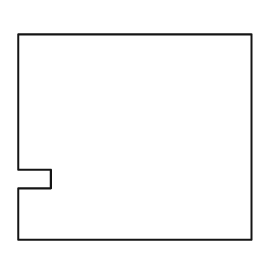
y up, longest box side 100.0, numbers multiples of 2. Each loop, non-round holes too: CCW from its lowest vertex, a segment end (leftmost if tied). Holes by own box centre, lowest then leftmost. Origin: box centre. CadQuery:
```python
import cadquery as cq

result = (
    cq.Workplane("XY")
    .moveTo(-50.0, -44.0)
    .lineTo(50.0, -44.0)
    .lineTo(50.0, 44.0)
    .lineTo(-50.0, 44.0)
    .lineTo(-50.0, -14.0)
    .lineTo(-36.0, -14.0)
    .lineTo(-36.0, -22.0)
    .lineTo(-50.0, -22.0)
    .close()
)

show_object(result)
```